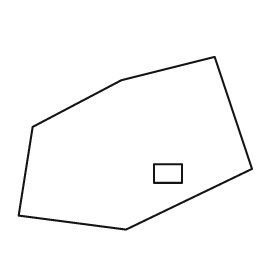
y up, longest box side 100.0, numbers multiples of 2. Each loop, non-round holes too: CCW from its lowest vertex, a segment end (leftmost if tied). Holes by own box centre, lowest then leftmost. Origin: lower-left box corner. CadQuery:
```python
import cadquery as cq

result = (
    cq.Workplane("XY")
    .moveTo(46.0, 0.0)
    .lineTo(100.0, 26.0)
    .lineTo(84.0, 74.0)
    .lineTo(44.0, 64.0)
    .lineTo(6.0, 44.0)
    .lineTo(0.0, 6.0)
    .close()
    .moveTo(58.0, 20.0)
    .lineTo(70.0, 20.0)
    .lineTo(70.0, 28.0)
    .lineTo(58.0, 28.0)
    .close()
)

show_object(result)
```